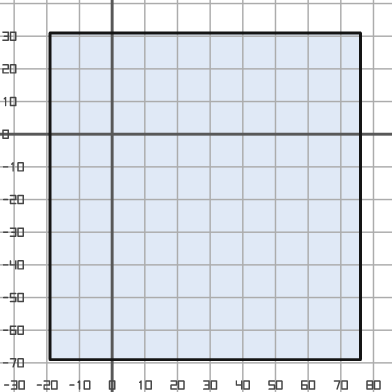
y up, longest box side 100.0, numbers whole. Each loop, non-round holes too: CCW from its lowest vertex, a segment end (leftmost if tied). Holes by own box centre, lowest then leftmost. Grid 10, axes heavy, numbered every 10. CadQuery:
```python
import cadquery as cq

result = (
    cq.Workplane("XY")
    .moveTo(-19.0, -69.0)
    .lineTo(76.0, -69.0)
    .lineTo(76.0, 31.0)
    .lineTo(-19.0, 31.0)
    .close()
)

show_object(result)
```